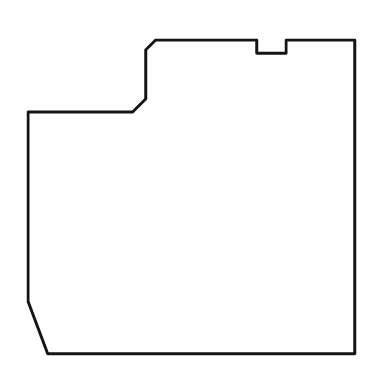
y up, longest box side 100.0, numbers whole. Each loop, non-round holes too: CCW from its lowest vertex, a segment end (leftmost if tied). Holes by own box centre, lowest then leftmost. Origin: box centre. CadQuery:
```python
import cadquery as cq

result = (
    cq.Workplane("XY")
    .moveTo(-44.0, -48.0)
    .lineTo(50.0, -48.0)
    .lineTo(50.0, 48.0)
    .lineTo(29.0, 48.0)
    .lineTo(29.0, 44.0)
    .lineTo(20.0, 44.0)
    .lineTo(20.0, 48.0)
    .lineTo(-11.0, 48.0)
    .lineTo(-14.0, 45.0)
    .lineTo(-14.0, 30.0)
    .lineTo(-18.0, 26.0)
    .lineTo(-50.0, 26.0)
    .lineTo(-50.0, -32.0)
    .close()
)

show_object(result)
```